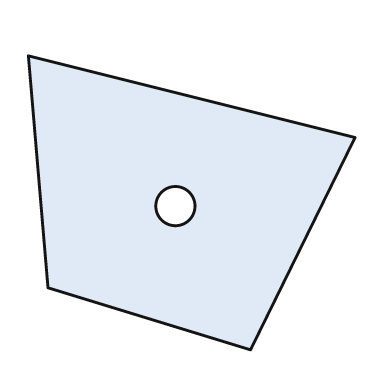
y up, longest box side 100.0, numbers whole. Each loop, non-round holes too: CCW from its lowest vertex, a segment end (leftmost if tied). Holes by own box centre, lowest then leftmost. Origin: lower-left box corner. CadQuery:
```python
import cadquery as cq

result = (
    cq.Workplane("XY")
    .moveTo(68.0, 0.0)
    .lineTo(100.0, 65.0)
    .lineTo(0.0, 90.0)
    .lineTo(6.0, 19.0)
    .close()
    .moveTo(45.0, 44.0)
    .circle(6.0)
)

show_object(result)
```